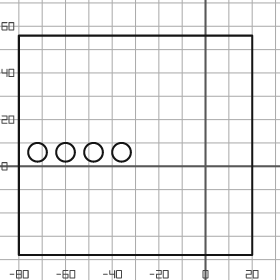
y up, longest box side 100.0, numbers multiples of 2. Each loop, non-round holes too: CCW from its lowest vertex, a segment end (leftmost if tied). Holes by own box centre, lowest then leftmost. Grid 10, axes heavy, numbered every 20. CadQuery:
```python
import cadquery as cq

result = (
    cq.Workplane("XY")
    .moveTo(-80.0, -38.0)
    .lineTo(20.0, -38.0)
    .lineTo(20.0, 56.0)
    .lineTo(-80.0, 56.0)
    .close()
    .moveTo(-72.0, 6.0)
    .circle(4.0)
    .moveTo(-60.0, 6.0)
    .circle(4.0)
    .moveTo(-48.0, 6.0)
    .circle(4.0)
    .moveTo(-36.0, 6.0)
    .circle(4.0)
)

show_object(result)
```